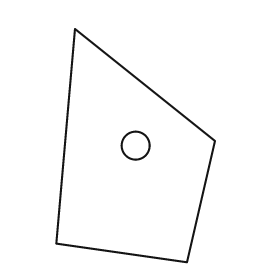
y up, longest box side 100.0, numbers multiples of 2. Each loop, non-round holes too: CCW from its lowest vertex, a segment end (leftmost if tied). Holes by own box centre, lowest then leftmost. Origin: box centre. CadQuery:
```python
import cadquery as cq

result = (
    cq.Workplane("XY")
    .moveTo(22.0, -50.0)
    .lineTo(34.0, 2.0)
    .lineTo(-26.0, 50.0)
    .lineTo(-34.0, -42.0)
    .close()
    .moveTo(0.0, 0.0)
    .circle(6.0)
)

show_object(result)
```